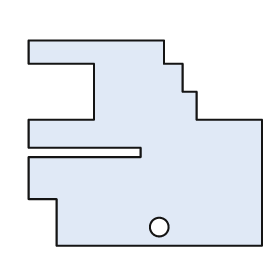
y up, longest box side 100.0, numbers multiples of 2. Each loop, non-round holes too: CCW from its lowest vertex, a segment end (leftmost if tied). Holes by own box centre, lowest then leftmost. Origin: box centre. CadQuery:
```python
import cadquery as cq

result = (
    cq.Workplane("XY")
    .moveTo(-38.0, -44.0)
    .lineTo(50.0, -44.0)
    .lineTo(50.0, 10.0)
    .lineTo(22.0, 10.0)
    .lineTo(22.0, 22.0)
    .lineTo(16.0, 22.0)
    .lineTo(16.0, 34.0)
    .lineTo(8.0, 34.0)
    .lineTo(8.0, 44.0)
    .lineTo(-50.0, 44.0)
    .lineTo(-50.0, 34.0)
    .lineTo(-22.0, 34.0)
    .lineTo(-22.0, 10.0)
    .lineTo(-50.0, 10.0)
    .lineTo(-50.0, -2.0)
    .lineTo(-2.0, -2.0)
    .lineTo(-2.0, -6.0)
    .lineTo(-50.0, -6.0)
    .lineTo(-50.0, -24.0)
    .lineTo(-38.0, -24.0)
    .close()
    .moveTo(6.0, -36.0)
    .circle(4.0)
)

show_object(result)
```